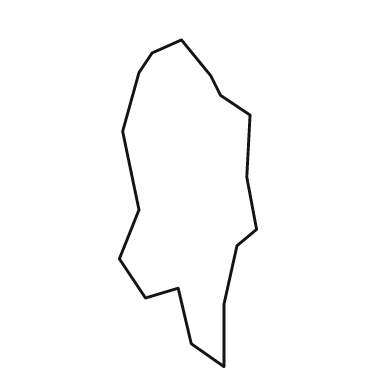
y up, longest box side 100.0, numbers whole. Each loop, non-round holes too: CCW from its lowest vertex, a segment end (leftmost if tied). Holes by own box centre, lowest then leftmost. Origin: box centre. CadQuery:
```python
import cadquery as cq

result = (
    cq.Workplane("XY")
    .moveTo(11.0, -50.0)
    .lineTo(11.0, -31.0)
    .lineTo(15.0, -13.0)
    .lineTo(21.0, -8.0)
    .lineTo(18.0, 8.0)
    .lineTo(19.0, 27.0)
    .lineTo(10.0, 33.0)
    .lineTo(7.0, 39.0)
    .lineTo(-2.0, 50.0)
    .lineTo(-11.0, 46.0)
    .lineTo(-15.0, 40.0)
    .lineTo(-20.0, 22.0)
    .lineTo(-15.0, -2.0)
    .lineTo(-21.0, -17.0)
    .lineTo(-13.0, -29.0)
    .lineTo(-3.0, -26.0)
    .lineTo(1.0, -43.0)
    .close()
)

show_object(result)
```